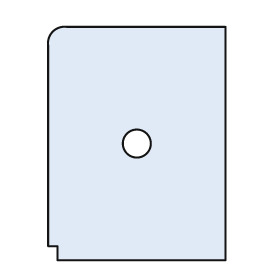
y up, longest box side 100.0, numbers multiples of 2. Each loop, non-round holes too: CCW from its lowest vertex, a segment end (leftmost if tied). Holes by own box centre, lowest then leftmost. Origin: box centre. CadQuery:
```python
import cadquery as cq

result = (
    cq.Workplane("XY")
    .moveTo(-34.0, -50.0)
    .lineTo(38.0, -50.0)
    .lineTo(38.0, 50.0)
    .lineTo(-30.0, 50.0)
    .threePointArc((-36.0, 48.0), (-38.0, 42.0))
    .lineTo(-38.0, -44.0)
    .lineTo(-34.0, -44.0)
    .close()
    .moveTo(0.0, 0.0)
    .circle(6.0)
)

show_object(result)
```